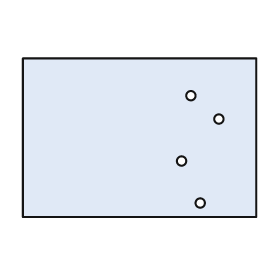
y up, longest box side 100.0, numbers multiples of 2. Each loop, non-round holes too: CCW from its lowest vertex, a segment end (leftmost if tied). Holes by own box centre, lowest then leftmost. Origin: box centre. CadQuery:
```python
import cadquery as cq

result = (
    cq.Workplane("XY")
    .moveTo(-50.0, -34.0)
    .lineTo(50.0, -34.0)
    .lineTo(50.0, 34.0)
    .lineTo(-50.0, 34.0)
    .close()
    .moveTo(26.0, -28.0)
    .circle(2.0)
    .moveTo(18.0, -10.0)
    .circle(2.0)
    .moveTo(34.0, 8.0)
    .circle(2.0)
    .moveTo(22.0, 18.0)
    .circle(2.0)
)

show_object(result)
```